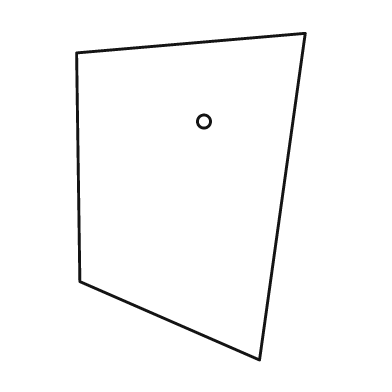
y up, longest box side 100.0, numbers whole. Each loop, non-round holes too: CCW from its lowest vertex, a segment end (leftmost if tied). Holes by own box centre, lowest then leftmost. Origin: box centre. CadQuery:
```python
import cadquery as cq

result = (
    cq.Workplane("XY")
    .moveTo(21.0, -50.0)
    .lineTo(35.0, 50.0)
    .lineTo(-35.0, 44.0)
    .lineTo(-34.0, -26.0)
    .close()
    .moveTo(4.0, 23.0)
    .circle(2.0)
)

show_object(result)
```